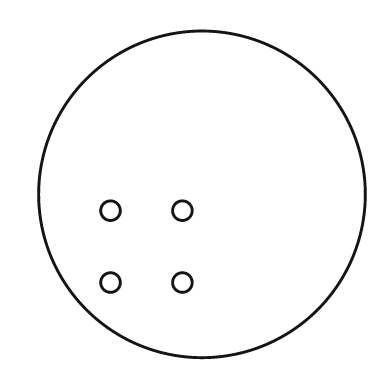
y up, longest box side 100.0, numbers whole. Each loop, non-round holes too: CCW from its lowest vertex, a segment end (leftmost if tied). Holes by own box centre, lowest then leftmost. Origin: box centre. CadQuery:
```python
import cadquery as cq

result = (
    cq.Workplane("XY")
    .moveTo(0.0, 0.0)
    .circle(50.0)
    .moveTo(-28.0, -27.0)
    .circle(3.0)
    .moveTo(-6.0, -27.0)
    .circle(3.0)
    .moveTo(-28.0, -5.0)
    .circle(3.0)
    .moveTo(-6.0, -5.0)
    .circle(3.0)
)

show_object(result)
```